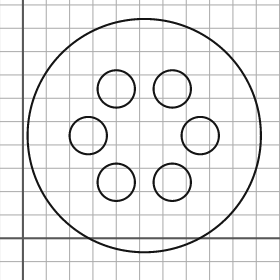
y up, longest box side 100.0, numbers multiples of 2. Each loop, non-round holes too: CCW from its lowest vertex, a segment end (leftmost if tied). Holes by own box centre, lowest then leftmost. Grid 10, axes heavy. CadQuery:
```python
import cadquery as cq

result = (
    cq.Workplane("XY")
    .moveTo(52.0, 44.0)
    .circle(50.0)
    .moveTo(40.0, 24.0)
    .circle(8.0)
    .moveTo(64.0, 24.0)
    .circle(8.0)
    .moveTo(28.0, 44.0)
    .circle(8.0)
    .moveTo(76.0, 44.0)
    .circle(8.0)
    .moveTo(40.0, 64.0)
    .circle(8.0)
    .moveTo(64.0, 64.0)
    .circle(8.0)
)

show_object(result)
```